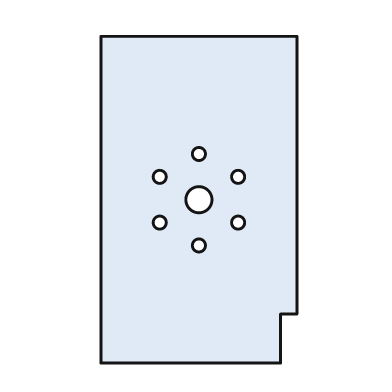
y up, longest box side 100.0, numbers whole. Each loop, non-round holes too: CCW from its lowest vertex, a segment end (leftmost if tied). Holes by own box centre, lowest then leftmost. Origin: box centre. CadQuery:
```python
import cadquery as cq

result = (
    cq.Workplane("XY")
    .moveTo(-30.0, -50.0)
    .lineTo(25.0, -50.0)
    .lineTo(25.0, -35.0)
    .lineTo(30.0, -35.0)
    .lineTo(30.0, 50.0)
    .lineTo(-30.0, 50.0)
    .close()
    .moveTo(0.0, -14.0)
    .circle(2.0)
    .moveTo(-12.0, -7.0)
    .circle(2.0)
    .moveTo(12.0, -7.0)
    .circle(2.0)
    .moveTo(0.0, 0.0)
    .circle(4.0)
    .moveTo(-12.0, 7.0)
    .circle(2.0)
    .moveTo(12.0, 7.0)
    .circle(2.0)
    .moveTo(0.0, 14.0)
    .circle(2.0)
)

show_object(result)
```